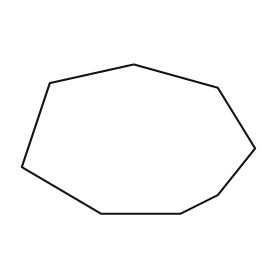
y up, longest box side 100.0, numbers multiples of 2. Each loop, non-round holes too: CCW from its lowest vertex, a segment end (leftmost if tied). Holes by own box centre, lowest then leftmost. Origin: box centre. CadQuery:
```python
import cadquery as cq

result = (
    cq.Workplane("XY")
    .moveTo(-16.0, -32.0)
    .lineTo(18.0, -32.0)
    .lineTo(34.0, -24.0)
    .lineTo(50.0, -4.0)
    .lineTo(34.0, 22.0)
    .lineTo(-2.0, 32.0)
    .lineTo(-38.0, 24.0)
    .lineTo(-50.0, -12.0)
    .close()
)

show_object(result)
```